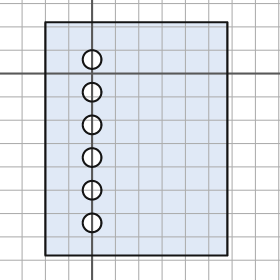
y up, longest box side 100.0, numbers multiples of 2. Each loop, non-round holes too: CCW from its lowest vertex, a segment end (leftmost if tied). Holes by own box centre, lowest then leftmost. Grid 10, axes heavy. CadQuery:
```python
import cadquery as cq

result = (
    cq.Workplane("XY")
    .moveTo(-20.0, -78.0)
    .lineTo(58.0, -78.0)
    .lineTo(58.0, 22.0)
    .lineTo(-20.0, 22.0)
    .close()
    .moveTo(0.0, -64.0)
    .circle(4.0)
    .moveTo(0.0, -50.0)
    .circle(4.0)
    .moveTo(0.0, -36.0)
    .circle(4.0)
    .moveTo(0.0, -22.0)
    .circle(4.0)
    .moveTo(0.0, -8.0)
    .circle(4.0)
    .moveTo(0.0, 6.0)
    .circle(4.0)
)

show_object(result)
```